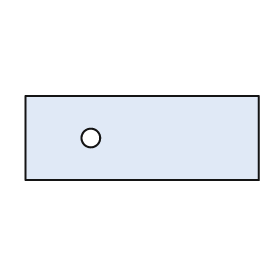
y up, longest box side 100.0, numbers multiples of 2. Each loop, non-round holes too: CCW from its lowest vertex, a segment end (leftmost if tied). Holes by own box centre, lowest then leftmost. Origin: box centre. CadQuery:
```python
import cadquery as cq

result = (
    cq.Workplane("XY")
    .moveTo(-50.0, -18.0)
    .lineTo(50.0, -18.0)
    .lineTo(50.0, 18.0)
    .lineTo(-50.0, 18.0)
    .close()
    .moveTo(-22.0, 0.0)
    .circle(4.0)
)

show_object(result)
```